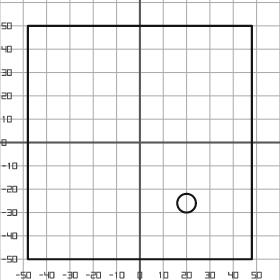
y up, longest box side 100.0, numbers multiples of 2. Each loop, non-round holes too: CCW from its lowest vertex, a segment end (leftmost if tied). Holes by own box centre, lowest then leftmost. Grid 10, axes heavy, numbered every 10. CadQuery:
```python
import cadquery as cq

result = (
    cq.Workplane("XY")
    .moveTo(-48.0, -50.0)
    .lineTo(48.0, -50.0)
    .lineTo(48.0, 50.0)
    .lineTo(-48.0, 50.0)
    .close()
    .moveTo(20.0, -26.0)
    .circle(4.0)
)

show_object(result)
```